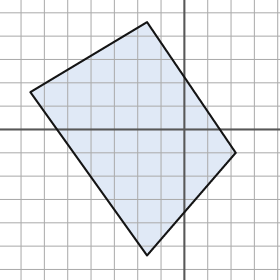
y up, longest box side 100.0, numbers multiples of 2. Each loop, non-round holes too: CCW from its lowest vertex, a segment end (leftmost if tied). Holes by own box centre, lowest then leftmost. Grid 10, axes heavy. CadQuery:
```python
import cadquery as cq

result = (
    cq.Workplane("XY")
    .moveTo(-16.0, -54.0)
    .lineTo(22.0, -10.0)
    .lineTo(-16.0, 46.0)
    .lineTo(-66.0, 16.0)
    .close()
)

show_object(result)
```